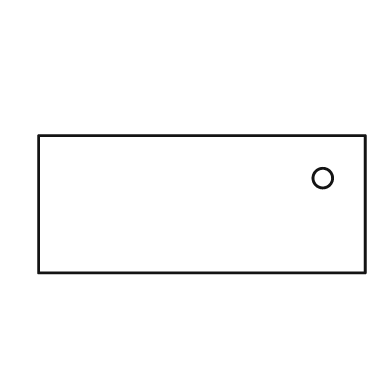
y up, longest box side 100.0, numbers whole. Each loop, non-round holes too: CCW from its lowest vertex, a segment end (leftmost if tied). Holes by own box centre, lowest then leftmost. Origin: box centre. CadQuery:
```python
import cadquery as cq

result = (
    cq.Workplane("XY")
    .moveTo(-50.0, -21.0)
    .lineTo(50.0, -21.0)
    .lineTo(50.0, 21.0)
    .lineTo(-50.0, 21.0)
    .close()
    .moveTo(37.0, 8.0)
    .circle(3.0)
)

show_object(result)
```